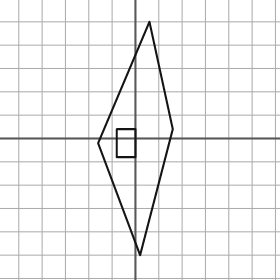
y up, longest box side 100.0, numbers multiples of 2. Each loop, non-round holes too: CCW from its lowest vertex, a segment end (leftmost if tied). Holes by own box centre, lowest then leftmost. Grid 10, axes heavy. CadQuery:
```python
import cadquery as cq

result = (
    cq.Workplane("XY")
    .moveTo(2.0, -50.0)
    .lineTo(16.0, 4.0)
    .lineTo(6.0, 50.0)
    .lineTo(-16.0, -2.0)
    .close()
    .moveTo(-8.0, -8.0)
    .lineTo(0.0, -8.0)
    .lineTo(0.0, 4.0)
    .lineTo(-8.0, 4.0)
    .close()
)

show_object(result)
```